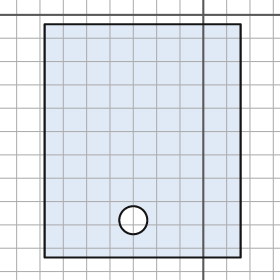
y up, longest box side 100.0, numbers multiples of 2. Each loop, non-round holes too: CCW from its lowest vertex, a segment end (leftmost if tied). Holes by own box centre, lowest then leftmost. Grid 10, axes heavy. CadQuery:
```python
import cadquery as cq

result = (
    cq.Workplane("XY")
    .moveTo(-68.0, -104.0)
    .lineTo(16.0, -104.0)
    .lineTo(16.0, -4.0)
    .lineTo(-68.0, -4.0)
    .close()
    .moveTo(-30.0, -88.0)
    .circle(6.0)
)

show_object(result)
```